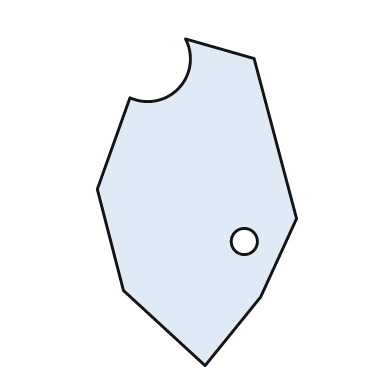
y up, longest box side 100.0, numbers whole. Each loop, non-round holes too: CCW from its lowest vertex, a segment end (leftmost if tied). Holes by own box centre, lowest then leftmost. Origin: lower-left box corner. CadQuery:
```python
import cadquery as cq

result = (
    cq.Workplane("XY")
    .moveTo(33.0, 0.0)
    .lineTo(50.0, 21.0)
    .lineTo(61.0, 45.0)
    .lineTo(48.0, 94.0)
    .lineTo(27.0, 100.0)
    .threePointArc((25.0, 85.0), (10.0, 82.0))
    .lineTo(0.0, 54.0)
    .lineTo(8.0, 23.0)
    .close()
    .moveTo(45.0, 38.0)
    .circle(4.0)
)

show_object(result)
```